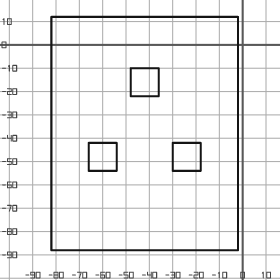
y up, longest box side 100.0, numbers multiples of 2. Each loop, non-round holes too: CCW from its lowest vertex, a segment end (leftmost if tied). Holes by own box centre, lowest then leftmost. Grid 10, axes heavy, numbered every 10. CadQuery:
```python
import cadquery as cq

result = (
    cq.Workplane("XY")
    .moveTo(-82.0, -88.0)
    .lineTo(-2.0, -88.0)
    .lineTo(-2.0, 12.0)
    .lineTo(-82.0, 12.0)
    .close()
    .moveTo(-66.0, -54.0)
    .lineTo(-54.0, -54.0)
    .lineTo(-54.0, -42.0)
    .lineTo(-66.0, -42.0)
    .close()
    .moveTo(-30.0, -54.0)
    .lineTo(-18.0, -54.0)
    .lineTo(-18.0, -42.0)
    .lineTo(-30.0, -42.0)
    .close()
    .moveTo(-48.0, -22.0)
    .lineTo(-36.0, -22.0)
    .lineTo(-36.0, -10.0)
    .lineTo(-48.0, -10.0)
    .close()
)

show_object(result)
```